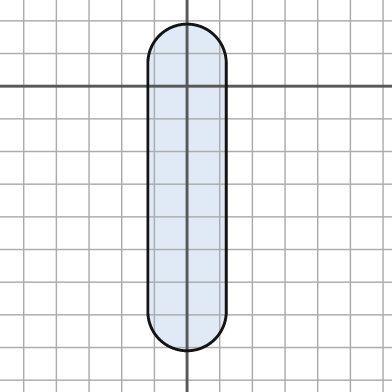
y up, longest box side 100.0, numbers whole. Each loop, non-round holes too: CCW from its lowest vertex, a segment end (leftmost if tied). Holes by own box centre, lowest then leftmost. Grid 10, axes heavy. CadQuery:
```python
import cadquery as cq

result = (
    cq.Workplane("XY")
    .moveTo(-12.0, -69.0)
    .threePointArc((0.0, -81.0), (12.0, -69.0))
    .lineTo(12.0, 7.0)
    .threePointArc((0.0, 19.0), (-12.0, 7.0))
    .close()
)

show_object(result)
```